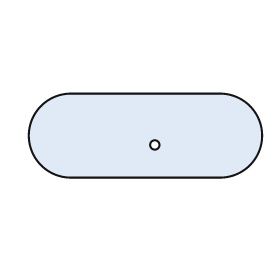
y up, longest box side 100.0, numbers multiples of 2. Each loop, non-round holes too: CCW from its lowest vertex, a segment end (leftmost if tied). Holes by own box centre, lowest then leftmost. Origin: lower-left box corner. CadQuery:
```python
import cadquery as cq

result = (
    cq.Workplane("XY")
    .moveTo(18.0, 0.0)
    .lineTo(82.0, 0.0)
    .threePointArc((100.0, 18.0), (82.0, 36.0))
    .lineTo(18.0, 36.0)
    .threePointArc((0.0, 18.0), (18.0, 0.0))
    .close()
    .moveTo(54.0, 14.0)
    .circle(2.0)
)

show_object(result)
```